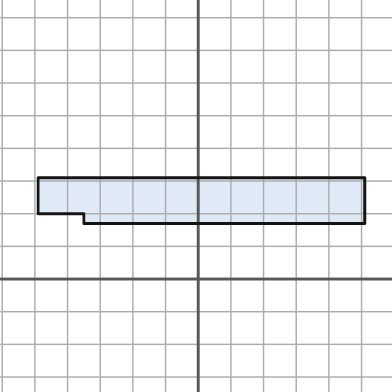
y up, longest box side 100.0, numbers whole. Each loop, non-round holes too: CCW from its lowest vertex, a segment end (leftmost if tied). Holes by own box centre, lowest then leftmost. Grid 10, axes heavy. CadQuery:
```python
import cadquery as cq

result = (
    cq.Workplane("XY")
    .moveTo(-35.0, 17.0)
    .lineTo(51.0, 17.0)
    .lineTo(51.0, 31.0)
    .lineTo(-49.0, 31.0)
    .lineTo(-49.0, 20.0)
    .lineTo(-35.0, 20.0)
    .close()
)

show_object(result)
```